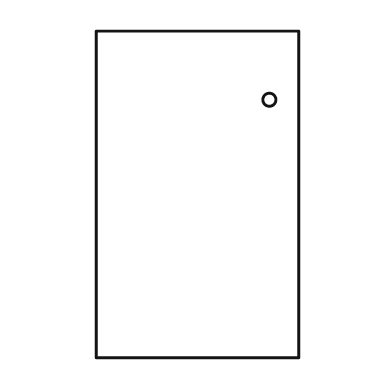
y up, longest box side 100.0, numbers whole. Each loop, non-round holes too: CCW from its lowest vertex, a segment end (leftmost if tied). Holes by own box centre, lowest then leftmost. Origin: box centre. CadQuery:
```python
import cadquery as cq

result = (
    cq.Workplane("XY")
    .moveTo(-31.0, -50.0)
    .lineTo(31.0, -50.0)
    .lineTo(31.0, 50.0)
    .lineTo(-31.0, 50.0)
    .close()
    .moveTo(22.0, 29.0)
    .circle(2.0)
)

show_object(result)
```